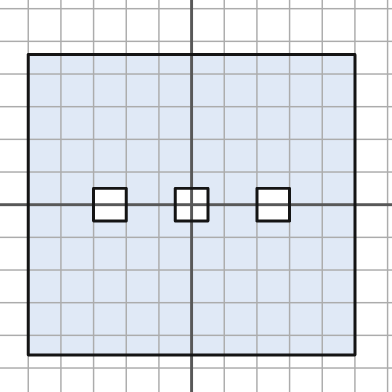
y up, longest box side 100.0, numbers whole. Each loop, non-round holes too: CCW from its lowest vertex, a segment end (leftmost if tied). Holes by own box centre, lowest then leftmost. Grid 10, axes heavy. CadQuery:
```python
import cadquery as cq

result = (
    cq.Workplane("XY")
    .moveTo(-50.0, -46.0)
    .lineTo(50.0, -46.0)
    .lineTo(50.0, 46.0)
    .lineTo(-50.0, 46.0)
    .close()
    .moveTo(-30.0, -5.0)
    .lineTo(-20.0, -5.0)
    .lineTo(-20.0, 5.0)
    .lineTo(-30.0, 5.0)
    .close()
    .moveTo(-5.0, -5.0)
    .lineTo(5.0, -5.0)
    .lineTo(5.0, 5.0)
    .lineTo(-5.0, 5.0)
    .close()
    .moveTo(20.0, -5.0)
    .lineTo(30.0, -5.0)
    .lineTo(30.0, 5.0)
    .lineTo(20.0, 5.0)
    .close()
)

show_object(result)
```